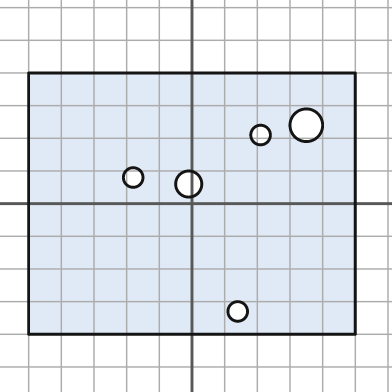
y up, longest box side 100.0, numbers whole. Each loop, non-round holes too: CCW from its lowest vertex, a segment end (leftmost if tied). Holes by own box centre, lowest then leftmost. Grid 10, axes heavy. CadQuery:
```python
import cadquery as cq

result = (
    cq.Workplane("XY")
    .moveTo(-50.0, -40.0)
    .lineTo(50.0, -40.0)
    .lineTo(50.0, 40.0)
    .lineTo(-50.0, 40.0)
    .close()
    .moveTo(14.0, -33.0)
    .circle(3.0)
    .moveTo(-1.0, 6.0)
    .circle(4.0)
    .moveTo(-18.0, 8.0)
    .circle(3.0)
    .moveTo(21.0, 21.0)
    .circle(3.0)
    .moveTo(35.0, 24.0)
    .circle(5.0)
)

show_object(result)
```